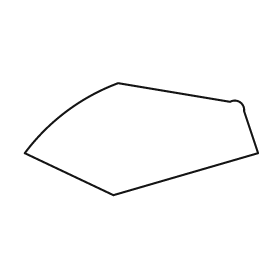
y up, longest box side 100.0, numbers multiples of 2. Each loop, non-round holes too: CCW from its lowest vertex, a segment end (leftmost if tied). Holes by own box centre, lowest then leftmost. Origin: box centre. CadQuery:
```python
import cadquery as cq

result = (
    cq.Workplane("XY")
    .moveTo(-12.0, -24.0)
    .lineTo(50.0, -6.0)
    .lineTo(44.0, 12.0)
    .threePointArc((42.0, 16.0), (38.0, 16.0))
    .lineTo(-10.0, 24.0)
    .threePointArc((-32.0, 12.0), (-50.0, -6.0))
    .close()
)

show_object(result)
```